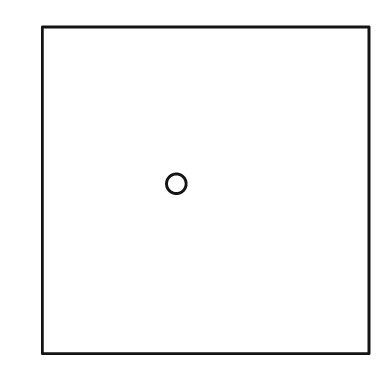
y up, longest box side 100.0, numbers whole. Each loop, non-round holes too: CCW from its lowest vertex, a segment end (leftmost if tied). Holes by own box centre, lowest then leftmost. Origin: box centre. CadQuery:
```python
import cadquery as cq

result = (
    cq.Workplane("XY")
    .moveTo(-50.0, -50.0)
    .lineTo(50.0, -50.0)
    .lineTo(50.0, 50.0)
    .lineTo(-50.0, 50.0)
    .close()
    .moveTo(-9.0, 2.0)
    .circle(3.0)
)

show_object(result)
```